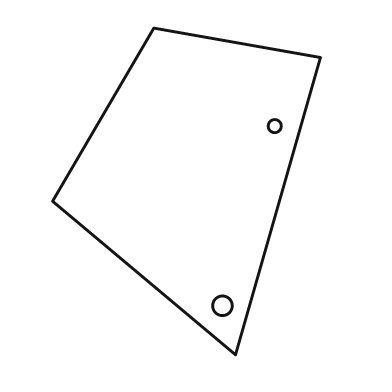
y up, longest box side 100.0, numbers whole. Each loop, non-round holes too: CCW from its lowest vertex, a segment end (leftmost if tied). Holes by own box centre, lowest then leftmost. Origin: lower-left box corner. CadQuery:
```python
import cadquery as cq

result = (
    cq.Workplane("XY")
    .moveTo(56.0, 0.0)
    .lineTo(82.0, 91.0)
    .lineTo(31.0, 100.0)
    .lineTo(0.0, 47.0)
    .close()
    .moveTo(52.0, 15.0)
    .circle(3.0)
    .moveTo(68.0, 70.0)
    .circle(2.0)
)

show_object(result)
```